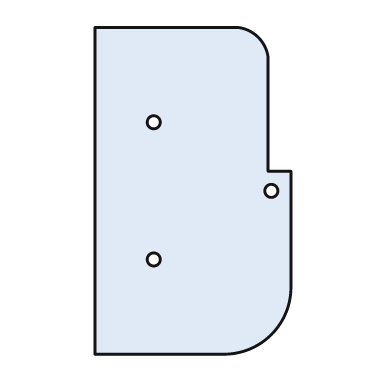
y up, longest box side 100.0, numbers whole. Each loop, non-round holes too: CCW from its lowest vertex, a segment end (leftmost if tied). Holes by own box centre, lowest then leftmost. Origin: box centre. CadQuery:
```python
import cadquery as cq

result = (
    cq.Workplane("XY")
    .moveTo(-30.0, -50.0)
    .lineTo(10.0, -50.0)
    .threePointArc((24.0, -44.0), (30.0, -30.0))
    .lineTo(30.0, 6.0)
    .lineTo(23.0, 6.0)
    .lineTo(23.0, 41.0)
    .threePointArc((20.0, 47.0), (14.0, 50.0))
    .lineTo(-30.0, 50.0)
    .close()
    .moveTo(-12.0, -21.0)
    .circle(2.0)
    .moveTo(24.0, 0.0)
    .circle(2.0)
    .moveTo(-12.0, 21.0)
    .circle(2.0)
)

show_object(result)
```